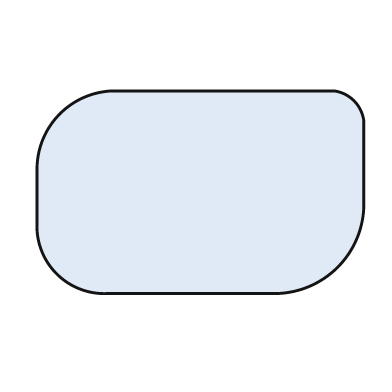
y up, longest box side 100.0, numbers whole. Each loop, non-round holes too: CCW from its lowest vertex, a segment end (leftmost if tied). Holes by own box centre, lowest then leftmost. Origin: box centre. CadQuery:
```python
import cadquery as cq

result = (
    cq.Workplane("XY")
    .moveTo(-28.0, -31.0)
    .lineTo(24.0, -31.0)
    .threePointArc((42.0, -23.0), (50.0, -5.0))
    .lineTo(50.0, 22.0)
    .threePointArc((47.0, 28.0), (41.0, 31.0))
    .lineTo(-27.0, 31.0)
    .threePointArc((-43.0, 24.0), (-50.0, 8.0))
    .lineTo(-50.0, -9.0)
    .threePointArc((-44.0, -25.0), (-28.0, -31.0))
    .close()
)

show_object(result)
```